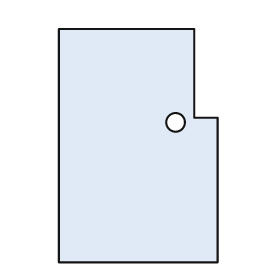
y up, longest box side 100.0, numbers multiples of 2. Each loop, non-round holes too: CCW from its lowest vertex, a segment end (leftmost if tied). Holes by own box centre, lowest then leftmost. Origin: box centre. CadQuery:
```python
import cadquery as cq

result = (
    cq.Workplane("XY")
    .moveTo(-34.0, -50.0)
    .lineTo(34.0, -50.0)
    .lineTo(34.0, 12.0)
    .lineTo(24.0, 12.0)
    .lineTo(24.0, 50.0)
    .lineTo(-34.0, 50.0)
    .close()
    .moveTo(16.0, 10.0)
    .circle(4.0)
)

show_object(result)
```